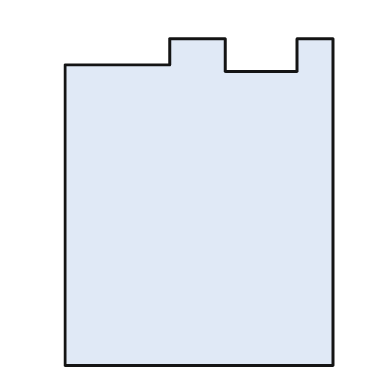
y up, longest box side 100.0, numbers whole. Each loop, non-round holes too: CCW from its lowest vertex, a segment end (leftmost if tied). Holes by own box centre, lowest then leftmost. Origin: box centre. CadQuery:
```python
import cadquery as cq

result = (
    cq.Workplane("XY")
    .moveTo(-41.0, -50.0)
    .lineTo(41.0, -50.0)
    .lineTo(41.0, 50.0)
    .lineTo(30.0, 50.0)
    .lineTo(30.0, 40.0)
    .lineTo(8.0, 40.0)
    .lineTo(8.0, 50.0)
    .lineTo(-9.0, 50.0)
    .lineTo(-9.0, 42.0)
    .lineTo(-41.0, 42.0)
    .close()
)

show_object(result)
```